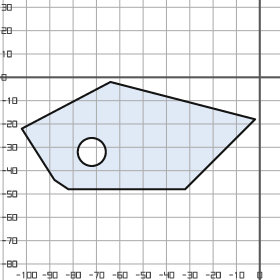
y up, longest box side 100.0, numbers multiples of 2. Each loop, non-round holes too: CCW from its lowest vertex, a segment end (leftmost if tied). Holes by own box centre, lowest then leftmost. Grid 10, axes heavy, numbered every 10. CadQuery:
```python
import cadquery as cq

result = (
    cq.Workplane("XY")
    .moveTo(-82.0, -48.0)
    .lineTo(-32.0, -48.0)
    .lineTo(-2.0, -18.0)
    .lineTo(-64.0, -2.0)
    .lineTo(-102.0, -22.0)
    .lineTo(-88.0, -44.0)
    .close()
    .moveTo(-72.0, -32.0)
    .circle(6.0)
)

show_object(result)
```